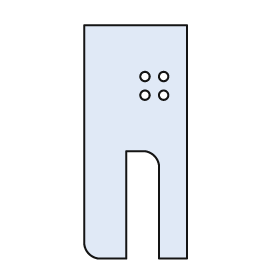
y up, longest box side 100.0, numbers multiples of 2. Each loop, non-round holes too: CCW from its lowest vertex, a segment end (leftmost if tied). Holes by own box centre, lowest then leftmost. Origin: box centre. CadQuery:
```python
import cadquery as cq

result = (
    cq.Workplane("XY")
    .moveTo(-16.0, -50.0)
    .lineTo(-4.0, -50.0)
    .lineTo(-4.0, -4.0)
    .lineTo(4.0, -4.0)
    .threePointArc((8.0, -6.0), (10.0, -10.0))
    .lineTo(10.0, -50.0)
    .lineTo(22.0, -50.0)
    .lineTo(22.0, 50.0)
    .lineTo(-22.0, 50.0)
    .lineTo(-22.0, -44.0)
    .threePointArc((-20.0, -48.0), (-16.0, -50.0))
    .close()
    .moveTo(4.0, 20.0)
    .circle(2.0)
    .moveTo(12.0, 20.0)
    .circle(2.0)
    .moveTo(4.0, 28.0)
    .circle(2.0)
    .moveTo(12.0, 28.0)
    .circle(2.0)
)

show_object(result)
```